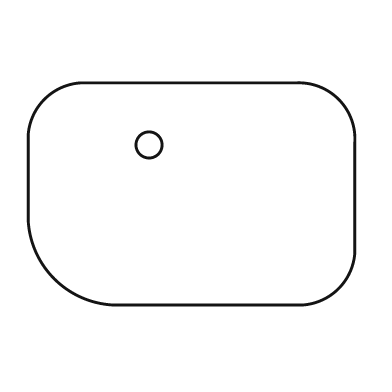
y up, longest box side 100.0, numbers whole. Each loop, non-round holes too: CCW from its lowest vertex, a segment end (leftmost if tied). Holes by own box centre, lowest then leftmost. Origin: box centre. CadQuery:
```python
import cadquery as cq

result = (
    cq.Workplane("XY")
    .moveTo(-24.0, -34.0)
    .lineTo(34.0, -34.0)
    .threePointArc((45.0, -29.0), (50.0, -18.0))
    .lineTo(50.0, 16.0)
    .threePointArc((45.0, 29.0), (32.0, 34.0))
    .lineTo(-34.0, 34.0)
    .threePointArc((-45.0, 29.0), (-50.0, 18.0))
    .lineTo(-50.0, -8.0)
    .threePointArc((-42.0, -26.0), (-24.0, -34.0))
    .close()
    .moveTo(-13.0, 15.0)
    .circle(4.0)
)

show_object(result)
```